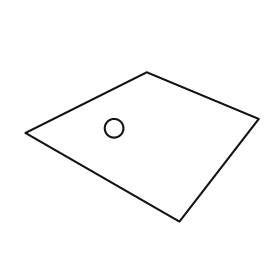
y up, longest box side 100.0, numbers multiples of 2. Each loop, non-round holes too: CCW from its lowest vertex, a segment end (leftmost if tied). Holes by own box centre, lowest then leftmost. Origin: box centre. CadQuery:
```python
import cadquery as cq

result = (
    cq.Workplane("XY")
    .moveTo(16.0, -32.0)
    .lineTo(50.0, 12.0)
    .lineTo(2.0, 32.0)
    .lineTo(-50.0, 6.0)
    .close()
    .moveTo(-12.0, 8.0)
    .circle(4.0)
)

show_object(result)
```